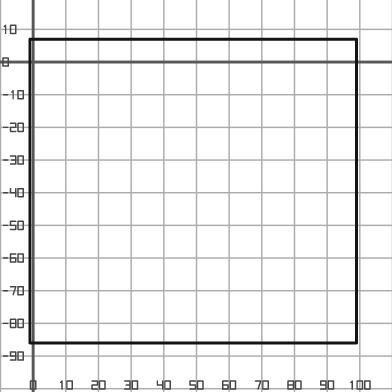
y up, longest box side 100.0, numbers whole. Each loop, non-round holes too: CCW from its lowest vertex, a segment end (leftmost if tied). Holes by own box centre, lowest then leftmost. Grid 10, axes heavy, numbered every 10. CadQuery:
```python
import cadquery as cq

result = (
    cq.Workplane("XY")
    .moveTo(-1.0, -86.0)
    .lineTo(99.0, -86.0)
    .lineTo(99.0, 7.0)
    .lineTo(-1.0, 7.0)
    .close()
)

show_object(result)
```